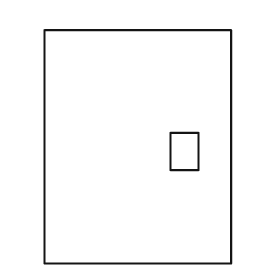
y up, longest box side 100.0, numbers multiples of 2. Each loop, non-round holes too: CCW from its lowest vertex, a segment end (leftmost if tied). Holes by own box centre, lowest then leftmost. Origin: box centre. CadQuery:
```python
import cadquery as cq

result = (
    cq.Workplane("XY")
    .moveTo(-40.0, -50.0)
    .lineTo(40.0, -50.0)
    .lineTo(40.0, 50.0)
    .lineTo(-40.0, 50.0)
    .close()
    .moveTo(14.0, -10.0)
    .lineTo(26.0, -10.0)
    .lineTo(26.0, 6.0)
    .lineTo(14.0, 6.0)
    .close()
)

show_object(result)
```